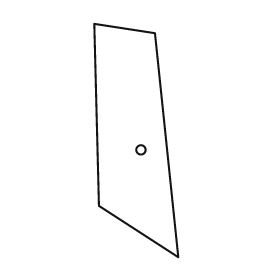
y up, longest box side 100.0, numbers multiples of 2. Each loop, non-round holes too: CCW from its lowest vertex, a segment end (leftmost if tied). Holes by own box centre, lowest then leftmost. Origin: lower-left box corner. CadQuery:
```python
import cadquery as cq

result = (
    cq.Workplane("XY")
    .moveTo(36.0, 0.0)
    .lineTo(26.0, 96.0)
    .lineTo(0.0, 100.0)
    .lineTo(2.0, 22.0)
    .close()
    .moveTo(20.0, 46.0)
    .circle(2.0)
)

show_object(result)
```